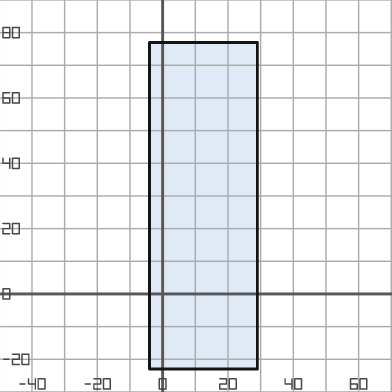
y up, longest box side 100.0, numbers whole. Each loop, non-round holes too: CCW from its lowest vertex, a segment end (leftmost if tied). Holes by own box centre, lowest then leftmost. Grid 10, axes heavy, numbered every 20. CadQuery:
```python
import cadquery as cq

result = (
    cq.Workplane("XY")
    .moveTo(-4.0, -23.0)
    .lineTo(29.0, -23.0)
    .lineTo(29.0, 77.0)
    .lineTo(-4.0, 77.0)
    .close()
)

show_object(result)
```